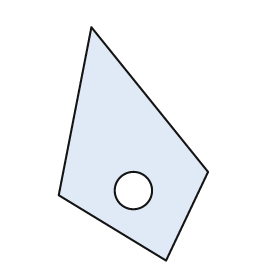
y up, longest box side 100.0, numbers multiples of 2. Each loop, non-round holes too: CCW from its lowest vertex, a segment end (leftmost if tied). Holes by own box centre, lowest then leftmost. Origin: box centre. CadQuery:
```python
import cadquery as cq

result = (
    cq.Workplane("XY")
    .moveTo(14.0, -50.0)
    .lineTo(32.0, -12.0)
    .lineTo(-18.0, 50.0)
    .lineTo(-32.0, -22.0)
    .close()
    .moveTo(0.0, -20.0)
    .circle(8.0)
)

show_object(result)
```